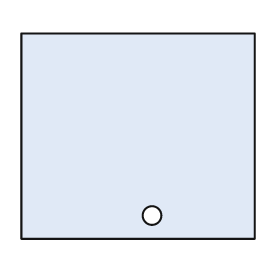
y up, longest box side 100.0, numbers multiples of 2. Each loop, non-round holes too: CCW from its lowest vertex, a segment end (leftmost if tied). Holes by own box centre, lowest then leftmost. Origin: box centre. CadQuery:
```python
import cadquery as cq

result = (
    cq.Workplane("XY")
    .moveTo(-50.0, -44.0)
    .lineTo(50.0, -44.0)
    .lineTo(50.0, 44.0)
    .lineTo(-50.0, 44.0)
    .close()
    .moveTo(6.0, -34.0)
    .circle(4.0)
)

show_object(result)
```